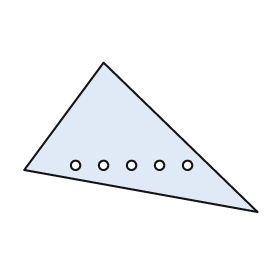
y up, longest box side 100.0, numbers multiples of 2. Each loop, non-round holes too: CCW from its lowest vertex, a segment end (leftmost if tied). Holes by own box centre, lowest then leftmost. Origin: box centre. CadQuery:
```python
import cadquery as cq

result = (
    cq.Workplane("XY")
    .moveTo(50.0, -32.0)
    .lineTo(-16.0, 32.0)
    .lineTo(-50.0, -14.0)
    .close()
    .moveTo(-28.0, -12.0)
    .circle(2.0)
    .moveTo(-16.0, -12.0)
    .circle(2.0)
    .moveTo(-4.0, -12.0)
    .circle(2.0)
    .moveTo(8.0, -12.0)
    .circle(2.0)
    .moveTo(20.0, -12.0)
    .circle(2.0)
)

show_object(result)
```